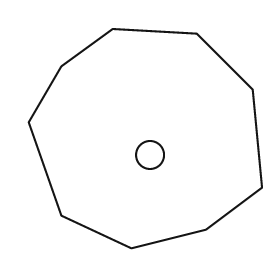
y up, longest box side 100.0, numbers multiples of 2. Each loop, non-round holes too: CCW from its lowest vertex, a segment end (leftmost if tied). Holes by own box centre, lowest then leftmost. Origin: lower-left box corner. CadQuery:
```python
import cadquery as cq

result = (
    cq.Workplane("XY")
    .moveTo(44.0, 0.0)
    .lineTo(76.0, 8.0)
    .lineTo(100.0, 26.0)
    .lineTo(96.0, 68.0)
    .lineTo(72.0, 92.0)
    .lineTo(36.0, 94.0)
    .lineTo(14.0, 78.0)
    .lineTo(0.0, 54.0)
    .lineTo(14.0, 14.0)
    .close()
    .moveTo(52.0, 40.0)
    .circle(6.0)
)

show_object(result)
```